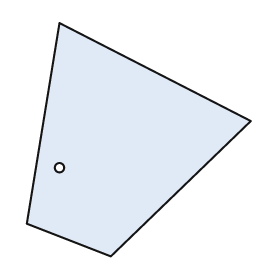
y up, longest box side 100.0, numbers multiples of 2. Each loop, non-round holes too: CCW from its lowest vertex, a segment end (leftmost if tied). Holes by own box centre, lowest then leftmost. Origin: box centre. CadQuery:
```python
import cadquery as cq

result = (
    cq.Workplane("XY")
    .moveTo(-12.0, -50.0)
    .lineTo(48.0, 8.0)
    .lineTo(-34.0, 50.0)
    .lineTo(-48.0, -36.0)
    .close()
    .moveTo(-34.0, -12.0)
    .circle(2.0)
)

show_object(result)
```